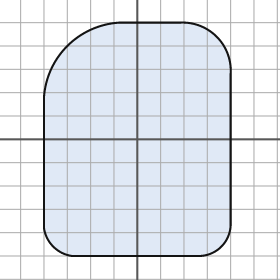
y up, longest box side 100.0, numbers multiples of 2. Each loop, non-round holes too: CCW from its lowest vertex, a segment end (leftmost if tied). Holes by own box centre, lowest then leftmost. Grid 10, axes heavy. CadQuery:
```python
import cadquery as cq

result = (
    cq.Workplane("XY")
    .moveTo(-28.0, -50.0)
    .lineTo(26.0, -50.0)
    .threePointArc((36.0, -46.0), (40.0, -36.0))
    .lineTo(40.0, 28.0)
    .threePointArc((34.0, 44.0), (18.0, 50.0))
    .lineTo(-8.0, 50.0)
    .threePointArc((-30.0, 40.0), (-40.0, 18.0))
    .lineTo(-40.0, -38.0)
    .threePointArc((-36.0, -46.0), (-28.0, -50.0))
    .close()
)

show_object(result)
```